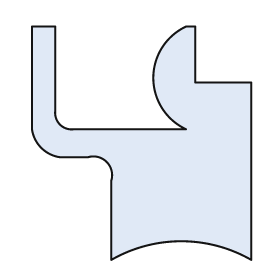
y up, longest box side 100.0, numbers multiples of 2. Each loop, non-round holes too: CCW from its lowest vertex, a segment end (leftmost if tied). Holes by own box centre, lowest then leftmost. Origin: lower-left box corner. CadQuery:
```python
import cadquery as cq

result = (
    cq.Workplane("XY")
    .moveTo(34.0, 0.0)
    .threePointArc((64.0, 8.0), (94.0, 0.0))
    .lineTo(94.0, 76.0)
    .lineTo(70.0, 76.0)
    .lineTo(70.0, 100.0)
    .lineTo(66.0, 100.0)
    .threePointArc((52.0, 78.0), (66.0, 56.0))
    .lineTo(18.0, 56.0)
    .threePointArc((12.0, 58.0), (10.0, 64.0))
    .lineTo(10.0, 100.0)
    .lineTo(0.0, 100.0)
    .lineTo(0.0, 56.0)
    .threePointArc((4.0, 48.0), (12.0, 44.0))
    .lineTo(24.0, 44.0)
    .threePointArc((32.0, 42.0), (34.0, 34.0))
    .close()
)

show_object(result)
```